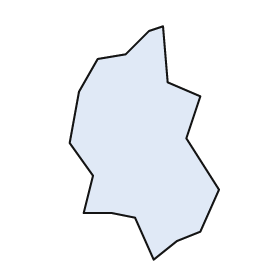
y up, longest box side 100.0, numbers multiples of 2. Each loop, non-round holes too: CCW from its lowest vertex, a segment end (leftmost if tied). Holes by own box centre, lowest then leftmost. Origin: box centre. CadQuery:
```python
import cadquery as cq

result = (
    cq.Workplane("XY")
    .moveTo(4.0, -50.0)
    .lineTo(14.0, -42.0)
    .lineTo(24.0, -38.0)
    .lineTo(32.0, -20.0)
    .lineTo(18.0, 2.0)
    .lineTo(24.0, 20.0)
    .lineTo(10.0, 26.0)
    .lineTo(8.0, 50.0)
    .lineTo(2.0, 48.0)
    .lineTo(-8.0, 38.0)
    .lineTo(-20.0, 36.0)
    .lineTo(-28.0, 22.0)
    .lineTo(-32.0, 0.0)
    .lineTo(-22.0, -14.0)
    .lineTo(-26.0, -30.0)
    .lineTo(-14.0, -30.0)
    .lineTo(-4.0, -32.0)
    .close()
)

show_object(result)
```